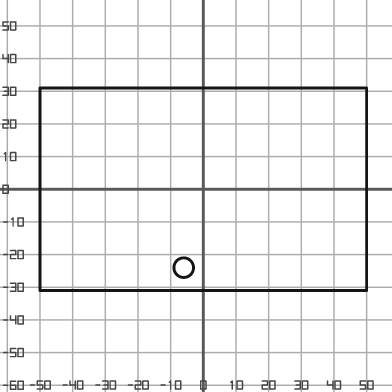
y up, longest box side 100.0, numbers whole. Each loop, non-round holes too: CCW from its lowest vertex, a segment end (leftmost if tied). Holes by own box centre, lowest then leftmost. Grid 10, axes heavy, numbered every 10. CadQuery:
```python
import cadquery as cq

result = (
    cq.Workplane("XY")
    .moveTo(-50.0, -31.0)
    .lineTo(50.0, -31.0)
    .lineTo(50.0, 31.0)
    .lineTo(-50.0, 31.0)
    .close()
    .moveTo(-6.0, -24.0)
    .circle(3.0)
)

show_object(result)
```